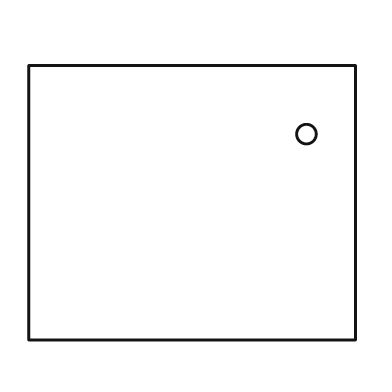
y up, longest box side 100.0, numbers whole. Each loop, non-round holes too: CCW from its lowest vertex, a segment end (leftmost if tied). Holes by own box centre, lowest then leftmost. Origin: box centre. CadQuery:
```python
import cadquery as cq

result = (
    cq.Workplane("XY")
    .moveTo(-50.0, -42.0)
    .lineTo(50.0, -42.0)
    .lineTo(50.0, 42.0)
    .lineTo(-50.0, 42.0)
    .close()
    .moveTo(35.0, 21.0)
    .circle(3.0)
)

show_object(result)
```